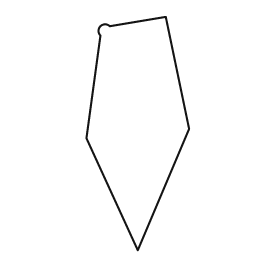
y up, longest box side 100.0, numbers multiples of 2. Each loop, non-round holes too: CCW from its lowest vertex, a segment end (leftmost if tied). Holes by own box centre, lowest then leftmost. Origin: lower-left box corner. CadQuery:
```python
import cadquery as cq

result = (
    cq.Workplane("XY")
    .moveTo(22.0, 0.0)
    .lineTo(44.0, 52.0)
    .lineTo(34.0, 100.0)
    .lineTo(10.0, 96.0)
    .threePointArc((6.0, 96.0), (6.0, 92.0))
    .lineTo(0.0, 48.0)
    .close()
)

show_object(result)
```